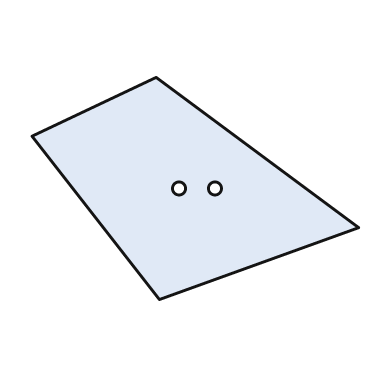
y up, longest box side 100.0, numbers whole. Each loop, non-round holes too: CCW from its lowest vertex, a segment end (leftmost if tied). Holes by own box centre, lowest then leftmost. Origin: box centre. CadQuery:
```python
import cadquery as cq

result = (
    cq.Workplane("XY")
    .moveTo(-11.0, -34.0)
    .lineTo(50.0, -12.0)
    .lineTo(-12.0, 34.0)
    .lineTo(-50.0, 16.0)
    .close()
    .moveTo(-5.0, 0.0)
    .circle(2.0)
    .moveTo(6.0, 0.0)
    .circle(2.0)
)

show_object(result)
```